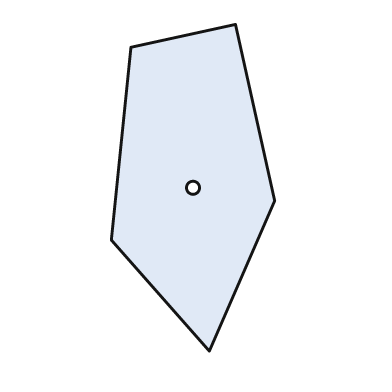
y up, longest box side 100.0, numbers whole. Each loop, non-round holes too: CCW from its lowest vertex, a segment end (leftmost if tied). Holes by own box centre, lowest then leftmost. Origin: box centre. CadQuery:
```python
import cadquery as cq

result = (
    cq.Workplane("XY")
    .moveTo(5.0, -50.0)
    .lineTo(25.0, -4.0)
    .lineTo(13.0, 50.0)
    .lineTo(-19.0, 43.0)
    .lineTo(-25.0, -16.0)
    .close()
    .moveTo(0.0, 0.0)
    .circle(2.0)
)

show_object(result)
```